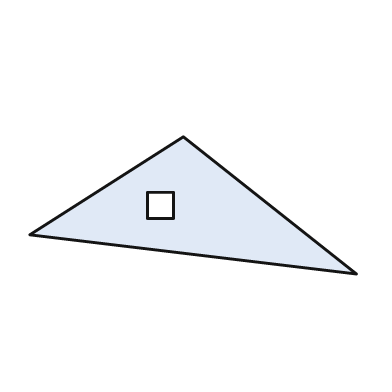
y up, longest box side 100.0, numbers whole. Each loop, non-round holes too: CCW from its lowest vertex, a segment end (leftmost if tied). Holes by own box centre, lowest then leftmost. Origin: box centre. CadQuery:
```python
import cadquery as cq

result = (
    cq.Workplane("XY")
    .moveTo(50.0, -21.0)
    .lineTo(-3.0, 21.0)
    .lineTo(-50.0, -9.0)
    .close()
    .moveTo(-14.0, -4.0)
    .lineTo(-6.0, -4.0)
    .lineTo(-6.0, 4.0)
    .lineTo(-14.0, 4.0)
    .close()
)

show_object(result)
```